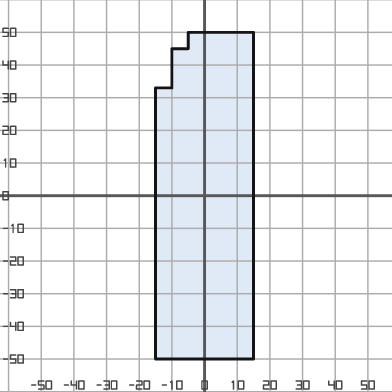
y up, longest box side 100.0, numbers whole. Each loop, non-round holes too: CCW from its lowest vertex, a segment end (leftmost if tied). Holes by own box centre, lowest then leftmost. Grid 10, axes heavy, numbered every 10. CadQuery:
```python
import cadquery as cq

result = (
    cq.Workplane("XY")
    .moveTo(-15.0, -50.0)
    .lineTo(15.0, -50.0)
    .lineTo(15.0, 50.0)
    .lineTo(-5.0, 50.0)
    .lineTo(-5.0, 45.0)
    .lineTo(-10.0, 45.0)
    .lineTo(-10.0, 33.0)
    .lineTo(-15.0, 33.0)
    .close()
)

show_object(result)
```